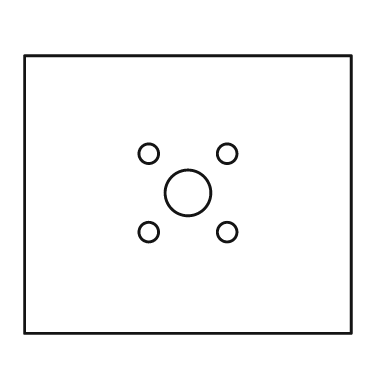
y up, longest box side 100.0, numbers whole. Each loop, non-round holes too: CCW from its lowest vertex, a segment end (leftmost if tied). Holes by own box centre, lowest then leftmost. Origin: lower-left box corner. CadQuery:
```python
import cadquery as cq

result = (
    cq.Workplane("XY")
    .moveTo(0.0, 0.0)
    .lineTo(100.0, 0.0)
    .lineTo(100.0, 85.0)
    .lineTo(0.0, 85.0)
    .close()
    .moveTo(38.0, 31.0)
    .circle(3.0)
    .moveTo(62.0, 31.0)
    .circle(3.0)
    .moveTo(50.0, 43.0)
    .circle(7.0)
    .moveTo(38.0, 55.0)
    .circle(3.0)
    .moveTo(62.0, 55.0)
    .circle(3.0)
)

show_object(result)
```